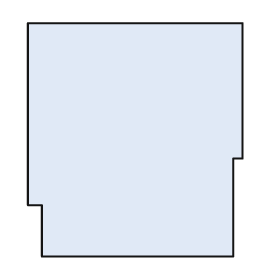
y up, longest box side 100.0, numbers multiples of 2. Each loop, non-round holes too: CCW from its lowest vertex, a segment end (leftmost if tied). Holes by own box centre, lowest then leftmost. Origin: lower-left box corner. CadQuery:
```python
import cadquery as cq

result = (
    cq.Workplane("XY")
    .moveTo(6.0, 0.0)
    .lineTo(88.0, 0.0)
    .lineTo(88.0, 42.0)
    .lineTo(92.0, 42.0)
    .lineTo(92.0, 100.0)
    .lineTo(0.0, 100.0)
    .lineTo(0.0, 22.0)
    .lineTo(6.0, 22.0)
    .close()
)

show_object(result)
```